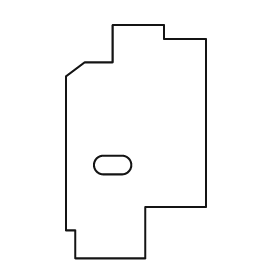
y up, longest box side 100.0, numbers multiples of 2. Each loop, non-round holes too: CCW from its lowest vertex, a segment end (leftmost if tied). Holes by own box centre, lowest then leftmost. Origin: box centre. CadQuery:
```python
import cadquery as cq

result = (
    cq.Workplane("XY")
    .moveTo(-26.0, -50.0)
    .lineTo(4.0, -50.0)
    .lineTo(4.0, -28.0)
    .lineTo(30.0, -28.0)
    .lineTo(30.0, 44.0)
    .lineTo(12.0, 44.0)
    .lineTo(12.0, 50.0)
    .lineTo(-10.0, 50.0)
    .lineTo(-10.0, 34.0)
    .lineTo(-22.0, 34.0)
    .lineTo(-30.0, 28.0)
    .lineTo(-30.0, -38.0)
    .lineTo(-26.0, -38.0)
    .close()
    .moveTo(-14.0, -14.0)
    .lineTo(-6.0, -14.0)
    .threePointArc((-2.0, -10.0), (-6.0, -6.0))
    .lineTo(-14.0, -6.0)
    .threePointArc((-18.0, -10.0), (-14.0, -14.0))
    .close()
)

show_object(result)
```